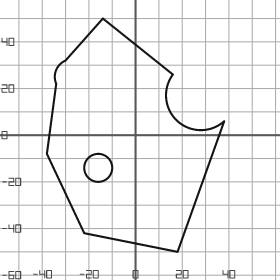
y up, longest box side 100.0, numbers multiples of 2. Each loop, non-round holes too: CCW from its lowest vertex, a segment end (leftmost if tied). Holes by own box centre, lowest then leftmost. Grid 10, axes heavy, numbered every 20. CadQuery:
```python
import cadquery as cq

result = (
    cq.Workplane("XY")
    .moveTo(18.0, -50.0)
    .lineTo(38.0, 6.0)
    .threePointArc((18.0, 6.0), (16.0, 26.0))
    .lineTo(-14.0, 50.0)
    .lineTo(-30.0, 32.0)
    .threePointArc((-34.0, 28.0), (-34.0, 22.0))
    .lineTo(-38.0, -8.0)
    .lineTo(-22.0, -42.0)
    .close()
    .moveTo(-16.0, -14.0)
    .circle(6.0)
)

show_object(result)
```